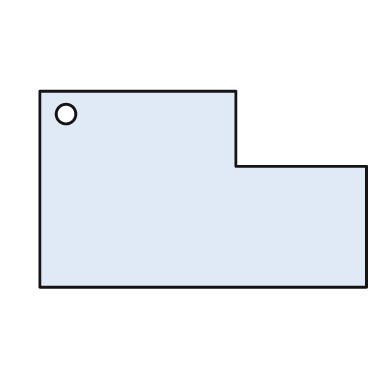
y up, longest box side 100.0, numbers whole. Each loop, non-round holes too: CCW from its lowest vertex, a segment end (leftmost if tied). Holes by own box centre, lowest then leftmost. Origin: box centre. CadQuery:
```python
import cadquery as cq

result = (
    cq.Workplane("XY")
    .moveTo(-50.0, -30.0)
    .lineTo(50.0, -30.0)
    .lineTo(50.0, 7.0)
    .lineTo(10.0, 7.0)
    .lineTo(10.0, 30.0)
    .lineTo(-50.0, 30.0)
    .close()
    .moveTo(-42.0, 23.0)
    .circle(3.0)
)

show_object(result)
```